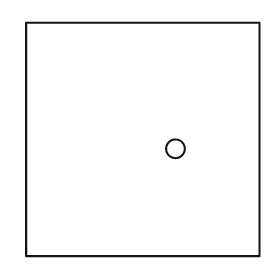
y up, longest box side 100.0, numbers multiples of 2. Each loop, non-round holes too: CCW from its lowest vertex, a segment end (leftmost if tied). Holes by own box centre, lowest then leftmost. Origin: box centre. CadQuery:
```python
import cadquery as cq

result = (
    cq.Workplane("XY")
    .moveTo(-50.0, -50.0)
    .lineTo(50.0, -50.0)
    .lineTo(50.0, 50.0)
    .lineTo(-50.0, 50.0)
    .close()
    .moveTo(14.0, -4.0)
    .circle(4.0)
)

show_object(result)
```